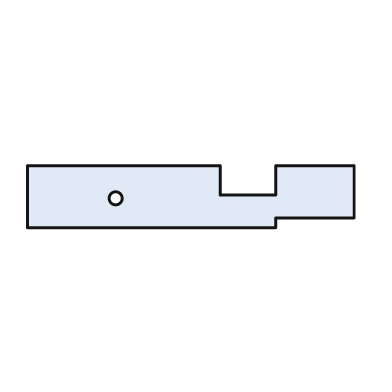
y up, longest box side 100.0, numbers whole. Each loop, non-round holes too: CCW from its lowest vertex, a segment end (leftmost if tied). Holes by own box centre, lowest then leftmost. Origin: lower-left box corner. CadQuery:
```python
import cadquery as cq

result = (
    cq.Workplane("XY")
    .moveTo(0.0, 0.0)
    .lineTo(76.0, 0.0)
    .lineTo(76.0, 3.0)
    .lineTo(100.0, 3.0)
    .lineTo(100.0, 19.0)
    .lineTo(76.0, 19.0)
    .lineTo(76.0, 10.0)
    .lineTo(59.0, 10.0)
    .lineTo(59.0, 19.0)
    .lineTo(0.0, 19.0)
    .close()
    .moveTo(27.0, 9.0)
    .circle(2.0)
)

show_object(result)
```